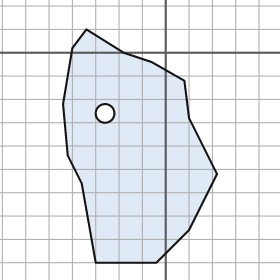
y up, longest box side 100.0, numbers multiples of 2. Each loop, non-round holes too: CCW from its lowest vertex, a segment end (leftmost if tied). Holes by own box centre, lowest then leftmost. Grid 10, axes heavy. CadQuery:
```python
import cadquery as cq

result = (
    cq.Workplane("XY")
    .moveTo(-30.0, -90.0)
    .lineTo(-4.0, -90.0)
    .lineTo(10.0, -76.0)
    .lineTo(22.0, -52.0)
    .lineTo(10.0, -28.0)
    .lineTo(8.0, -12.0)
    .lineTo(-6.0, -4.0)
    .lineTo(-18.0, 0.0)
    .lineTo(-34.0, 10.0)
    .lineTo(-40.0, 2.0)
    .lineTo(-44.0, -22.0)
    .lineTo(-42.0, -44.0)
    .lineTo(-36.0, -56.0)
    .close()
    .moveTo(-26.0, -26.0)
    .circle(4.0)
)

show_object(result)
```